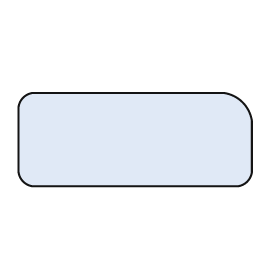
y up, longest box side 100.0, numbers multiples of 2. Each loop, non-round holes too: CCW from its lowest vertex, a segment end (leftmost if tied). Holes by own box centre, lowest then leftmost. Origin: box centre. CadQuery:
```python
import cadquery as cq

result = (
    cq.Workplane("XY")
    .moveTo(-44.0, -20.0)
    .lineTo(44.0, -20.0)
    .threePointArc((48.0, -18.0), (50.0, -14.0))
    .lineTo(50.0, 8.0)
    .threePointArc((46.0, 16.0), (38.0, 20.0))
    .lineTo(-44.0, 20.0)
    .threePointArc((-48.0, 18.0), (-50.0, 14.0))
    .lineTo(-50.0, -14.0)
    .threePointArc((-48.0, -18.0), (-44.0, -20.0))
    .close()
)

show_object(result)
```